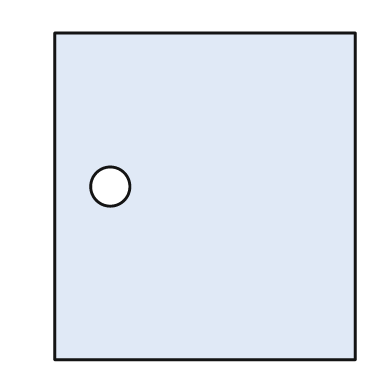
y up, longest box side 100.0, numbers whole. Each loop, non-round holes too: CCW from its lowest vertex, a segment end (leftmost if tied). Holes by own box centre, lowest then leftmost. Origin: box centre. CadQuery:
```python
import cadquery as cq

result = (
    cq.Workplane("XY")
    .moveTo(-46.0, -50.0)
    .lineTo(46.0, -50.0)
    .lineTo(46.0, 50.0)
    .lineTo(-46.0, 50.0)
    .close()
    .moveTo(-29.0, 3.0)
    .circle(6.0)
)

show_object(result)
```